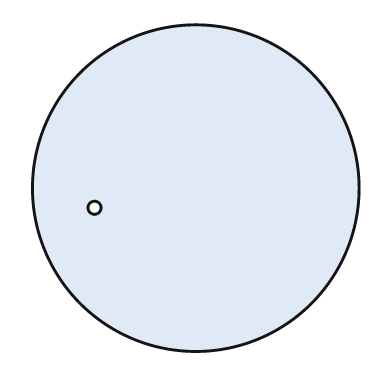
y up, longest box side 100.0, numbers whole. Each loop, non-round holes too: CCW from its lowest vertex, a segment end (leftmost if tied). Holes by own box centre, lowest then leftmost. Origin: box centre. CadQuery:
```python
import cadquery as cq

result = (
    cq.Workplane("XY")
    .moveTo(0.0, 0.0)
    .circle(50.0)
    .moveTo(-31.0, -6.0)
    .circle(2.0)
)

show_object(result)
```